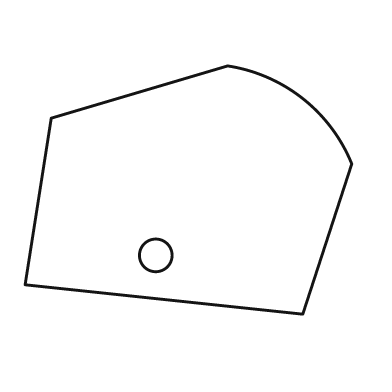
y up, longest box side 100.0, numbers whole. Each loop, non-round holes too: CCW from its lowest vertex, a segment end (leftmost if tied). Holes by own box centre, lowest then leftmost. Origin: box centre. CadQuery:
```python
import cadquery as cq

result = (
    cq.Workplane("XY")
    .moveTo(35.0, -38.0)
    .lineTo(50.0, 8.0)
    .threePointArc((35.0, 28.0), (12.0, 38.0))
    .lineTo(-42.0, 22.0)
    .lineTo(-50.0, -29.0)
    .close()
    .moveTo(-10.0, -20.0)
    .circle(5.0)
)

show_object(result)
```